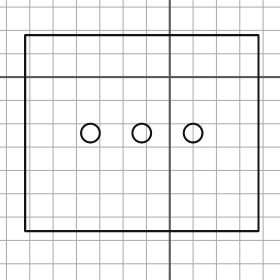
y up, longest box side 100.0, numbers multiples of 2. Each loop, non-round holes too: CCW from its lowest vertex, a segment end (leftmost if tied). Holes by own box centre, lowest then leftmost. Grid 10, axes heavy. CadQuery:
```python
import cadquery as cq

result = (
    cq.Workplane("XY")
    .moveTo(-62.0, -66.0)
    .lineTo(38.0, -66.0)
    .lineTo(38.0, 18.0)
    .lineTo(-62.0, 18.0)
    .close()
    .moveTo(-34.0, -24.0)
    .circle(4.0)
    .moveTo(-12.0, -24.0)
    .circle(4.0)
    .moveTo(10.0, -24.0)
    .circle(4.0)
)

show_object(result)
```